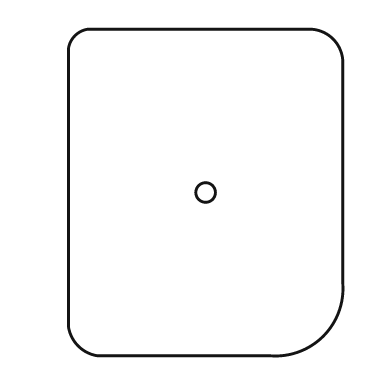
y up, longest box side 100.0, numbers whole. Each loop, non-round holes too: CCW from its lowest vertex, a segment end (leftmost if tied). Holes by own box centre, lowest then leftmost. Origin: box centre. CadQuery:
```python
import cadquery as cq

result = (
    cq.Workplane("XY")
    .moveTo(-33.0, -50.0)
    .lineTo(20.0, -50.0)
    .threePointArc((36.0, -44.0), (42.0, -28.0))
    .lineTo(42.0, 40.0)
    .threePointArc((39.0, 47.0), (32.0, 50.0))
    .lineTo(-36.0, 50.0)
    .threePointArc((-40.0, 48.0), (-42.0, 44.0))
    .lineTo(-42.0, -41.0)
    .threePointArc((-39.0, -47.0), (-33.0, -50.0))
    .close()
    .moveTo(0.0, 0.0)
    .circle(3.0)
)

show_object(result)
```